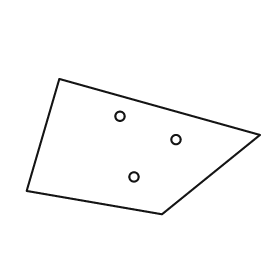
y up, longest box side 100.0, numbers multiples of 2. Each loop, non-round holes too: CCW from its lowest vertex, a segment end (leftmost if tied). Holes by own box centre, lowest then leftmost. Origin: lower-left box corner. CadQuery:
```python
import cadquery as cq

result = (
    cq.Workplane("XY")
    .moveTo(58.0, 0.0)
    .lineTo(100.0, 34.0)
    .lineTo(14.0, 58.0)
    .lineTo(0.0, 10.0)
    .close()
    .moveTo(46.0, 16.0)
    .circle(2.0)
    .moveTo(64.0, 32.0)
    .circle(2.0)
    .moveTo(40.0, 42.0)
    .circle(2.0)
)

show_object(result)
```